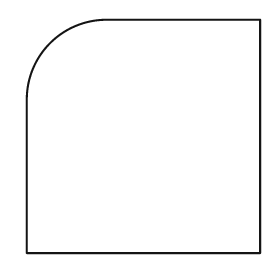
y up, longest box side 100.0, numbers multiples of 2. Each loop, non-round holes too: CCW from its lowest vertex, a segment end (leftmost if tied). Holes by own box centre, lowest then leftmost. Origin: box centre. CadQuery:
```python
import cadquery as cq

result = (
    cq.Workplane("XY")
    .moveTo(-50.0, -50.0)
    .lineTo(50.0, -50.0)
    .lineTo(50.0, 50.0)
    .lineTo(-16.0, 50.0)
    .threePointArc((-40.0, 40.0), (-50.0, 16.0))
    .close()
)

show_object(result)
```